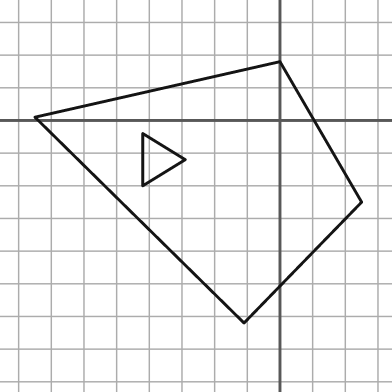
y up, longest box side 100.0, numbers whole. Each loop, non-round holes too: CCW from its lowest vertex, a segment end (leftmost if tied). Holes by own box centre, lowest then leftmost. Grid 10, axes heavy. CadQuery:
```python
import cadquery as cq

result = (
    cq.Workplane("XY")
    .moveTo(-11.0, -62.0)
    .lineTo(25.0, -25.0)
    .lineTo(0.0, 18.0)
    .lineTo(-75.0, 1.0)
    .close()
    .moveTo(-42.0, -20.0)
    .lineTo(-29.0, -12.0)
    .lineTo(-42.0, -4.0)
    .close()
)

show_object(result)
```